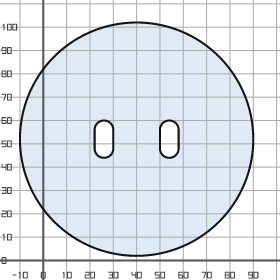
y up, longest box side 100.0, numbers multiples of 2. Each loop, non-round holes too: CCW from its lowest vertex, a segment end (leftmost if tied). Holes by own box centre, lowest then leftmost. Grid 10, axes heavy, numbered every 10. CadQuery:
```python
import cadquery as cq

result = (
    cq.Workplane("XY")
    .moveTo(40.0, 52.0)
    .circle(50.0)
    .moveTo(22.0, 48.0)
    .threePointArc((26.0, 44.0), (30.0, 48.0))
    .lineTo(30.0, 56.0)
    .threePointArc((26.0, 60.0), (22.0, 56.0))
    .close()
    .moveTo(50.0, 48.0)
    .threePointArc((54.0, 44.0), (58.0, 48.0))
    .lineTo(58.0, 56.0)
    .threePointArc((54.0, 60.0), (50.0, 56.0))
    .close()
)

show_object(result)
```